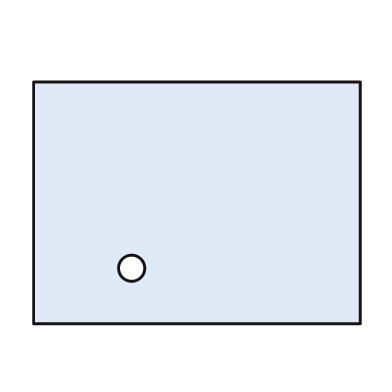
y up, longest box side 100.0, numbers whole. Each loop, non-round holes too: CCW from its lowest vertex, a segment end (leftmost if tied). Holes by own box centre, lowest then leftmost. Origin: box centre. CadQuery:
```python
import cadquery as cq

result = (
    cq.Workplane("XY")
    .moveTo(-50.0, -37.0)
    .lineTo(50.0, -37.0)
    .lineTo(50.0, 37.0)
    .lineTo(-50.0, 37.0)
    .close()
    .moveTo(-20.0, -20.0)
    .circle(4.0)
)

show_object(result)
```